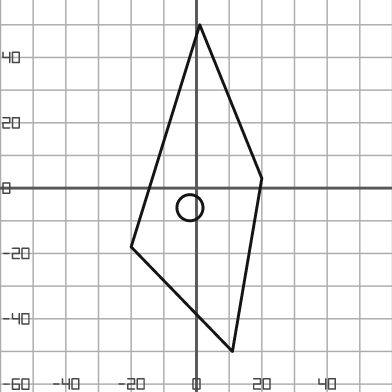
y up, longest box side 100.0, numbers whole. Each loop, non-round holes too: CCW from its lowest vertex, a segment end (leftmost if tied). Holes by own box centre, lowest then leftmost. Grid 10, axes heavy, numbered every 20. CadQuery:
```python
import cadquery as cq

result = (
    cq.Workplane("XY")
    .moveTo(11.0, -50.0)
    .lineTo(20.0, 3.0)
    .lineTo(1.0, 50.0)
    .lineTo(-20.0, -18.0)
    .close()
    .moveTo(-2.0, -6.0)
    .circle(4.0)
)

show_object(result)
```